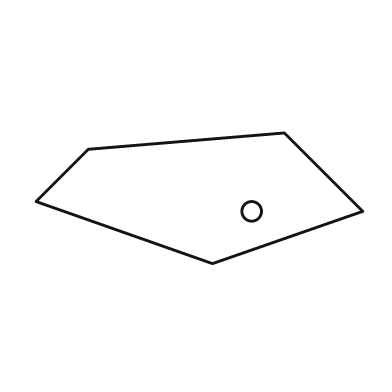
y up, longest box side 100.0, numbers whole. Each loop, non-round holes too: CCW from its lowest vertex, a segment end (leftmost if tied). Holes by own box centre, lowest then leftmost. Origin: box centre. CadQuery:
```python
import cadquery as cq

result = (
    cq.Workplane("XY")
    .moveTo(4.0, -20.0)
    .lineTo(50.0, -4.0)
    .lineTo(26.0, 20.0)
    .lineTo(-34.0, 15.0)
    .lineTo(-50.0, -1.0)
    .close()
    .moveTo(16.0, -4.0)
    .circle(3.0)
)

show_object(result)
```